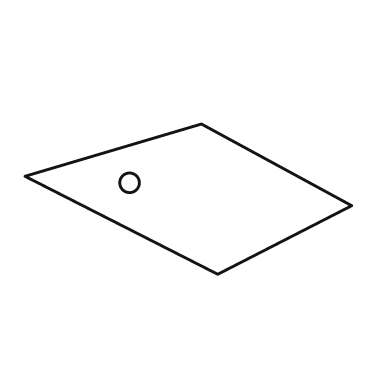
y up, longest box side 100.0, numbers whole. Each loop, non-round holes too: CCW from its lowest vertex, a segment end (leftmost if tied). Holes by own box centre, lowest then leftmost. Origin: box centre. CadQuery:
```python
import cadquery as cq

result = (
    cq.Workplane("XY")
    .moveTo(9.0, -23.0)
    .lineTo(50.0, -2.0)
    .lineTo(4.0, 23.0)
    .lineTo(-50.0, 7.0)
    .close()
    .moveTo(-18.0, 5.0)
    .circle(3.0)
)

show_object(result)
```